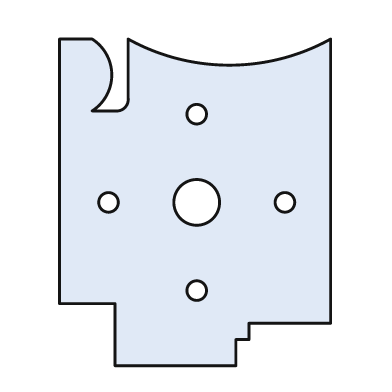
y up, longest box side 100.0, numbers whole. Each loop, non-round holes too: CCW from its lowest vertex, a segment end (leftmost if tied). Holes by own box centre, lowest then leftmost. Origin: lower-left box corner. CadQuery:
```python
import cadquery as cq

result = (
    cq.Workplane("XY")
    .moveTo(17.0, 0.0)
    .lineTo(54.0, 0.0)
    .lineTo(54.0, 8.0)
    .lineTo(58.0, 8.0)
    .lineTo(58.0, 13.0)
    .lineTo(83.0, 13.0)
    .lineTo(83.0, 100.0)
    .threePointArc((52.0, 92.0), (21.0, 100.0))
    .lineTo(21.0, 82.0)
    .threePointArc((20.0, 79.0), (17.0, 78.0))
    .lineTo(10.0, 78.0)
    .threePointArc((16.0, 89.0), (10.0, 100.0))
    .lineTo(0.0, 100.0)
    .lineTo(0.0, 19.0)
    .lineTo(17.0, 19.0)
    .close()
    .moveTo(42.0, 23.0)
    .circle(3.0)
    .moveTo(15.0, 50.0)
    .circle(3.0)
    .moveTo(42.0, 50.0)
    .circle(7.0)
    .moveTo(69.0, 50.0)
    .circle(3.0)
    .moveTo(42.0, 77.0)
    .circle(3.0)
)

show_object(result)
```